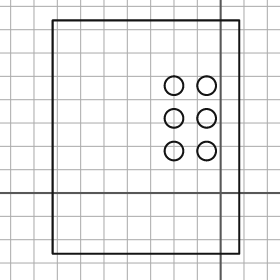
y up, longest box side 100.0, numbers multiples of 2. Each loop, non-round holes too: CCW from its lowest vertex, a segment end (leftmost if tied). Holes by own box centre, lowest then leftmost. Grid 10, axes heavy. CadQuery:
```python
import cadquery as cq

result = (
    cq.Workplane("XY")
    .moveTo(-72.0, -26.0)
    .lineTo(8.0, -26.0)
    .lineTo(8.0, 74.0)
    .lineTo(-72.0, 74.0)
    .close()
    .moveTo(-20.0, 18.0)
    .circle(4.0)
    .moveTo(-6.0, 18.0)
    .circle(4.0)
    .moveTo(-20.0, 32.0)
    .circle(4.0)
    .moveTo(-6.0, 32.0)
    .circle(4.0)
    .moveTo(-20.0, 46.0)
    .circle(4.0)
    .moveTo(-6.0, 46.0)
    .circle(4.0)
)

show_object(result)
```